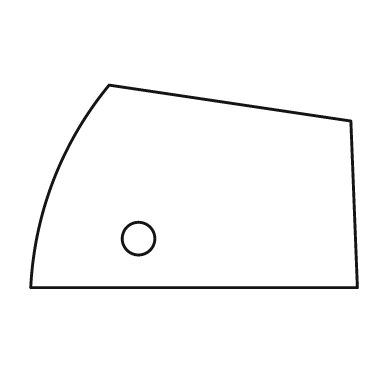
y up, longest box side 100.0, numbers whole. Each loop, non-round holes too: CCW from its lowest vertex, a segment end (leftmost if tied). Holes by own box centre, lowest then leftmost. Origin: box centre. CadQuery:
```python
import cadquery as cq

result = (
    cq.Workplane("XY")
    .moveTo(-50.0, -31.0)
    .lineTo(50.0, -31.0)
    .lineTo(48.0, 20.0)
    .lineTo(-26.0, 31.0)
    .threePointArc((-43.0, 2.0), (-50.0, -31.0))
    .close()
    .moveTo(-17.0, -16.0)
    .circle(5.0)
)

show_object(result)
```